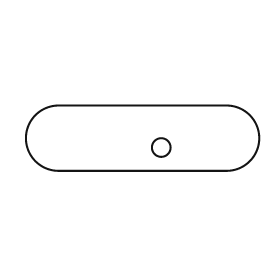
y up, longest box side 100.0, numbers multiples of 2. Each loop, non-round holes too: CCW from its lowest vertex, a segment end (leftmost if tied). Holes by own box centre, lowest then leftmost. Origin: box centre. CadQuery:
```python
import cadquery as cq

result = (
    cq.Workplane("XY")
    .moveTo(-36.0, -14.0)
    .lineTo(36.0, -14.0)
    .threePointArc((50.0, 0.0), (36.0, 14.0))
    .lineTo(-36.0, 14.0)
    .threePointArc((-50.0, 0.0), (-36.0, -14.0))
    .close()
    .moveTo(8.0, -4.0)
    .circle(4.0)
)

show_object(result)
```